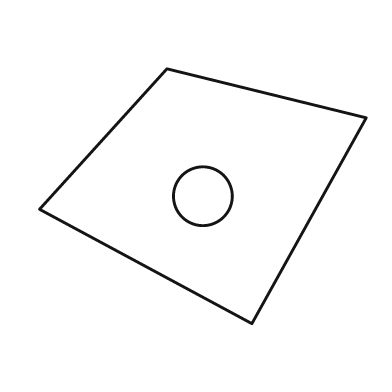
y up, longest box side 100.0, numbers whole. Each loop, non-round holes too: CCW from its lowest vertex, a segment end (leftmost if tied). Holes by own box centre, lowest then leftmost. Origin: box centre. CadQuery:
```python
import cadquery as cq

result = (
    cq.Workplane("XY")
    .moveTo(15.0, -39.0)
    .lineTo(50.0, 24.0)
    .lineTo(-11.0, 39.0)
    .lineTo(-50.0, -4.0)
    .close()
    .moveTo(0.0, 0.0)
    .circle(9.0)
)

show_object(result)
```